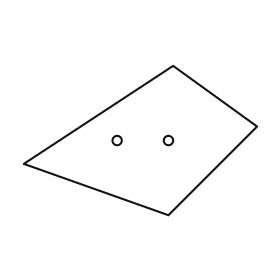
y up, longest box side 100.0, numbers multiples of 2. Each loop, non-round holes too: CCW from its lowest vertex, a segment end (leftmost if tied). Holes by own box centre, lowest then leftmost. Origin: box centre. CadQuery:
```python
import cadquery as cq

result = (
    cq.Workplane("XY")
    .moveTo(12.0, -32.0)
    .lineTo(50.0, 6.0)
    .lineTo(14.0, 32.0)
    .lineTo(-50.0, -10.0)
    .close()
    .moveTo(-10.0, 0.0)
    .circle(2.0)
    .moveTo(12.0, 0.0)
    .circle(2.0)
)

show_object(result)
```